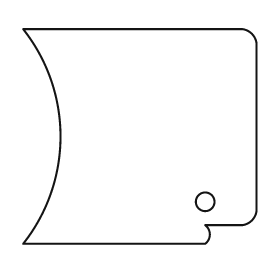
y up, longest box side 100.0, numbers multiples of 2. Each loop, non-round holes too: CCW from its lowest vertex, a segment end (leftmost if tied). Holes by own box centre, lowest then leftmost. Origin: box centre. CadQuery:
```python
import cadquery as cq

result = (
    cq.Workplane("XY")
    .moveTo(-50.0, -46.0)
    .lineTo(28.0, -46.0)
    .threePointArc((30.0, -42.0), (28.0, -38.0))
    .lineTo(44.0, -38.0)
    .threePointArc((48.0, -36.0), (50.0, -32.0))
    .lineTo(50.0, 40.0)
    .threePointArc((48.0, 44.0), (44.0, 46.0))
    .lineTo(-50.0, 46.0)
    .threePointArc((-34.0, 0.0), (-50.0, -46.0))
    .close()
    .moveTo(28.0, -28.0)
    .circle(4.0)
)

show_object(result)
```